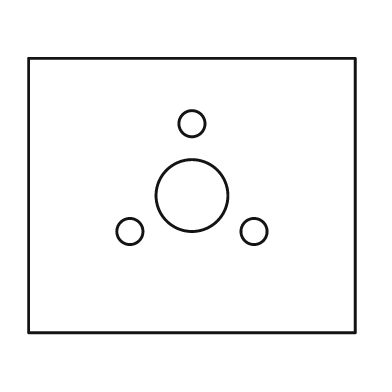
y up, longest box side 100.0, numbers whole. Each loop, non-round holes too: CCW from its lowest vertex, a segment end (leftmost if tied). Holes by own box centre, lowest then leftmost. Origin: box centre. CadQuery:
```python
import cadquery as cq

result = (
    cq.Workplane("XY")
    .moveTo(-50.0, -42.0)
    .lineTo(50.0, -42.0)
    .lineTo(50.0, 42.0)
    .lineTo(-50.0, 42.0)
    .close()
    .moveTo(-19.0, -11.0)
    .circle(4.0)
    .moveTo(19.0, -11.0)
    .circle(4.0)
    .moveTo(0.0, 0.0)
    .circle(11.0)
    .moveTo(0.0, 22.0)
    .circle(4.0)
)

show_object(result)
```